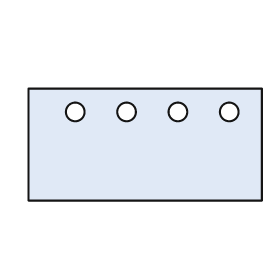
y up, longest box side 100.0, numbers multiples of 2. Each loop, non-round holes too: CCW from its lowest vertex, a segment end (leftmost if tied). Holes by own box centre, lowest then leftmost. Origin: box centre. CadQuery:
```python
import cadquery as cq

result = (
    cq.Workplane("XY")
    .moveTo(-50.0, -24.0)
    .lineTo(50.0, -24.0)
    .lineTo(50.0, 24.0)
    .lineTo(-50.0, 24.0)
    .close()
    .moveTo(-30.0, 14.0)
    .circle(4.0)
    .moveTo(-8.0, 14.0)
    .circle(4.0)
    .moveTo(14.0, 14.0)
    .circle(4.0)
    .moveTo(36.0, 14.0)
    .circle(4.0)
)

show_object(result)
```